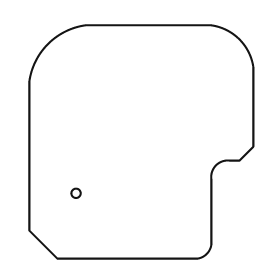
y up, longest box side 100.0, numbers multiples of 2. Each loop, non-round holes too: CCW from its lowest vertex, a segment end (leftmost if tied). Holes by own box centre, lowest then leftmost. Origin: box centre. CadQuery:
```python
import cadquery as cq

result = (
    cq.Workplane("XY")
    .moveTo(-36.0, -50.0)
    .lineTo(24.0, -50.0)
    .threePointArc((28.0, -48.0), (30.0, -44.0))
    .lineTo(30.0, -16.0)
    .threePointArc((32.0, -10.0), (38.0, -8.0))
    .lineTo(42.0, -8.0)
    .lineTo(48.0, -2.0)
    .lineTo(48.0, 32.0)
    .threePointArc((42.0, 44.0), (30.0, 50.0))
    .lineTo(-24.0, 50.0)
    .threePointArc((-40.0, 42.0), (-48.0, 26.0))
    .lineTo(-48.0, -38.0)
    .close()
    .moveTo(-28.0, -22.0)
    .circle(2.0)
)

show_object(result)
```